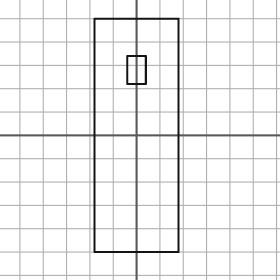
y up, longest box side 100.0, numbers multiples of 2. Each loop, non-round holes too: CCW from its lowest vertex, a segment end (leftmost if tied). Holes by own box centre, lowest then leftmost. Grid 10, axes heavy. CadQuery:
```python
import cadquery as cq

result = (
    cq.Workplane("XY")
    .moveTo(-18.0, -50.0)
    .lineTo(18.0, -50.0)
    .lineTo(18.0, 50.0)
    .lineTo(-18.0, 50.0)
    .close()
    .moveTo(-4.0, 22.0)
    .lineTo(4.0, 22.0)
    .lineTo(4.0, 34.0)
    .lineTo(-4.0, 34.0)
    .close()
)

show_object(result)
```